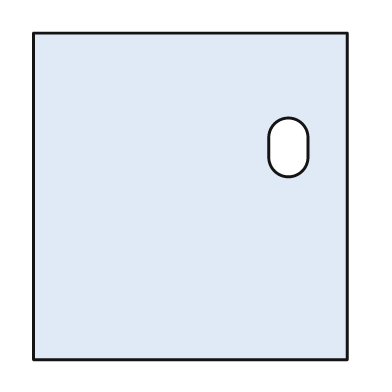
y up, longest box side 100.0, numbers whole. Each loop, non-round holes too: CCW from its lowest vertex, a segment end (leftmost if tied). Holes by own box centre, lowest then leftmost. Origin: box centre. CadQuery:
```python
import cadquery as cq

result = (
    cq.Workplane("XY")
    .moveTo(-48.0, -50.0)
    .lineTo(48.0, -50.0)
    .lineTo(48.0, 50.0)
    .lineTo(-48.0, 50.0)
    .close()
    .moveTo(24.0, 12.0)
    .threePointArc((30.0, 6.0), (36.0, 12.0))
    .lineTo(36.0, 18.0)
    .threePointArc((30.0, 24.0), (24.0, 18.0))
    .close()
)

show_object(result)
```